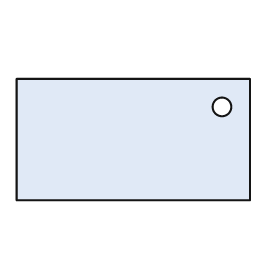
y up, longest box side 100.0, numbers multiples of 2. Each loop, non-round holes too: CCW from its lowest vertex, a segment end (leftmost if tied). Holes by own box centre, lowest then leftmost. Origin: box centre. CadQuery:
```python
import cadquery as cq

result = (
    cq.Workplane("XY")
    .moveTo(-50.0, -26.0)
    .lineTo(50.0, -26.0)
    .lineTo(50.0, 26.0)
    .lineTo(-50.0, 26.0)
    .close()
    .moveTo(38.0, 14.0)
    .circle(4.0)
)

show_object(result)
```